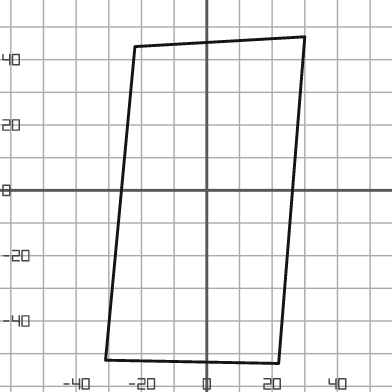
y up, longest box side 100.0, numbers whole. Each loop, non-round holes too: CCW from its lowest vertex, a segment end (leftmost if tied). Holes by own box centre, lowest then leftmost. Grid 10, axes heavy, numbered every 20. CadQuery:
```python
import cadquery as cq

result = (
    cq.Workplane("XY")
    .moveTo(22.0, -53.0)
    .lineTo(30.0, 47.0)
    .lineTo(-22.0, 44.0)
    .lineTo(-31.0, -52.0)
    .close()
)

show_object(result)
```